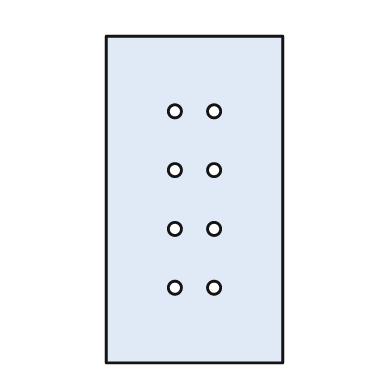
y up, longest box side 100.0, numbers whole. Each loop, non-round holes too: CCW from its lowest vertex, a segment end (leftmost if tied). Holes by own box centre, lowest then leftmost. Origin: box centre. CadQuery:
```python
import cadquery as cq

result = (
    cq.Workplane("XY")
    .moveTo(-27.0, -50.0)
    .lineTo(27.0, -50.0)
    .lineTo(27.0, 50.0)
    .lineTo(-27.0, 50.0)
    .close()
    .moveTo(-6.0, -27.0)
    .circle(2.0)
    .moveTo(6.0, -27.0)
    .circle(2.0)
    .moveTo(-6.0, -9.0)
    .circle(2.0)
    .moveTo(6.0, -9.0)
    .circle(2.0)
    .moveTo(-6.0, 9.0)
    .circle(2.0)
    .moveTo(6.0, 9.0)
    .circle(2.0)
    .moveTo(-6.0, 27.0)
    .circle(2.0)
    .moveTo(6.0, 27.0)
    .circle(2.0)
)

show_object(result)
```